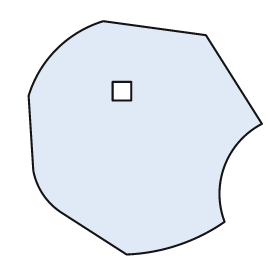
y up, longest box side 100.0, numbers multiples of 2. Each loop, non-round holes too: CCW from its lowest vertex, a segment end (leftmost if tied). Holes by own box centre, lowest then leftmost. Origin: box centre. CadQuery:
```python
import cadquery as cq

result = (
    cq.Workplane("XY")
    .moveTo(-8.0, -50.0)
    .threePointArc((14.0, -46.0), (34.0, -36.0))
    .threePointArc((34.0, -12.0), (50.0, 6.0))
    .lineTo(26.0, 44.0)
    .lineTo(-18.0, 50.0)
    .threePointArc((-38.0, 38.0), (-50.0, 18.0))
    .lineTo(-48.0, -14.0)
    .threePointArc((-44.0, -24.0), (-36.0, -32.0))
    .close()
    .moveTo(-14.0, 16.0)
    .lineTo(-6.0, 16.0)
    .lineTo(-6.0, 24.0)
    .lineTo(-14.0, 24.0)
    .close()
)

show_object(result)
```